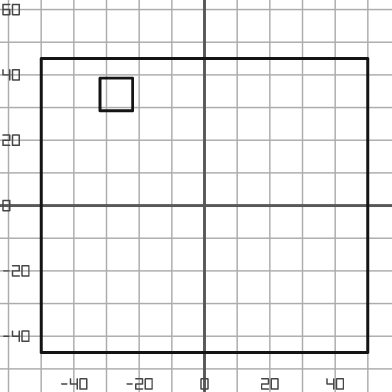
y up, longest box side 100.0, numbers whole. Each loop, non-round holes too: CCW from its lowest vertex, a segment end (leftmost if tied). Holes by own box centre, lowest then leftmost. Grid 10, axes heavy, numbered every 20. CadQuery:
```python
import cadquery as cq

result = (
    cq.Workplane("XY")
    .moveTo(-50.0, -45.0)
    .lineTo(50.0, -45.0)
    .lineTo(50.0, 45.0)
    .lineTo(-50.0, 45.0)
    .close()
    .moveTo(-32.0, 29.0)
    .lineTo(-22.0, 29.0)
    .lineTo(-22.0, 39.0)
    .lineTo(-32.0, 39.0)
    .close()
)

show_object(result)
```